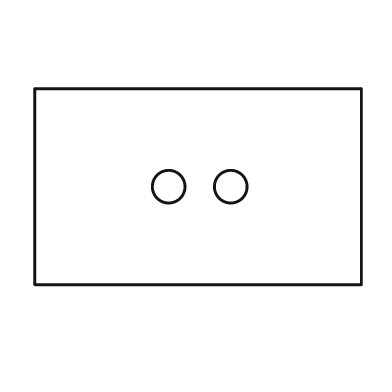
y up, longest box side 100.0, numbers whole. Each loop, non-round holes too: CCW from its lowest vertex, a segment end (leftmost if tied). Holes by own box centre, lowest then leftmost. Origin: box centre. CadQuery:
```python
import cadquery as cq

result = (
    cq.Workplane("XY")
    .moveTo(-50.0, -30.0)
    .lineTo(50.0, -30.0)
    .lineTo(50.0, 30.0)
    .lineTo(-50.0, 30.0)
    .close()
    .moveTo(-9.0, 0.0)
    .circle(5.0)
    .moveTo(10.0, 0.0)
    .circle(5.0)
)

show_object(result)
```